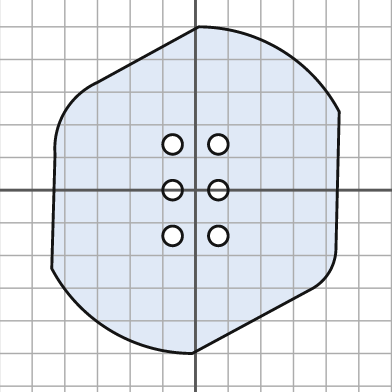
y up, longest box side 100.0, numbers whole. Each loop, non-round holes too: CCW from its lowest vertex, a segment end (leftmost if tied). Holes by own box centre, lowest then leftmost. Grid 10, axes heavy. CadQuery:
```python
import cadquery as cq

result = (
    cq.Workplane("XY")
    .moveTo(-1.0, -50.0)
    .lineTo(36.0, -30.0)
    .threePointArc((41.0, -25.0), (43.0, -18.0))
    .lineTo(44.0, 24.0)
    .threePointArc((26.0, 43.0), (1.0, 50.0))
    .lineTo(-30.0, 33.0)
    .threePointArc((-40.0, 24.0), (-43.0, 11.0))
    .lineTo(-44.0, -24.0)
    .threePointArc((-26.0, -43.0), (-1.0, -50.0))
    .close()
    .moveTo(-7.0, -14.0)
    .circle(3.0)
    .moveTo(7.0, -14.0)
    .circle(3.0)
    .moveTo(-7.0, 0.0)
    .circle(3.0)
    .moveTo(7.0, 0.0)
    .circle(3.0)
    .moveTo(-7.0, 14.0)
    .circle(3.0)
    .moveTo(7.0, 14.0)
    .circle(3.0)
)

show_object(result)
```